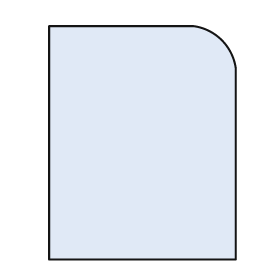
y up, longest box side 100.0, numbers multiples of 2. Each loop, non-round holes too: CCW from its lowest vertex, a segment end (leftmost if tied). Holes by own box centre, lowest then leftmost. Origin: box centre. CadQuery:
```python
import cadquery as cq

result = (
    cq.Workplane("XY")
    .moveTo(-40.0, -50.0)
    .lineTo(40.0, -50.0)
    .lineTo(40.0, 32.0)
    .threePointArc((34.0, 44.0), (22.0, 50.0))
    .lineTo(-40.0, 50.0)
    .close()
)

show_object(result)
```